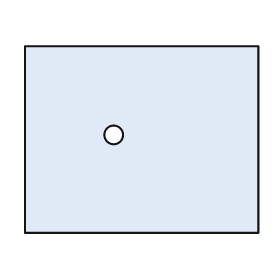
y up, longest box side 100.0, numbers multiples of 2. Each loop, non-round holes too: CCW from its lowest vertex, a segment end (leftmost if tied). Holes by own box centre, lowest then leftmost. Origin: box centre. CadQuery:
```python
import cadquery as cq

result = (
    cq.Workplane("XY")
    .moveTo(-50.0, -40.0)
    .lineTo(50.0, -40.0)
    .lineTo(50.0, 40.0)
    .lineTo(-50.0, 40.0)
    .close()
    .moveTo(-12.0, 2.0)
    .circle(4.0)
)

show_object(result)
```